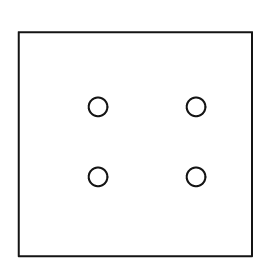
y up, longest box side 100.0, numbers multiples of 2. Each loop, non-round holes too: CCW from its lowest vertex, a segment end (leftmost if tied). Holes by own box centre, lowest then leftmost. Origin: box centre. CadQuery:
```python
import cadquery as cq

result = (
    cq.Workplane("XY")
    .moveTo(-50.0, -48.0)
    .lineTo(50.0, -48.0)
    .lineTo(50.0, 48.0)
    .lineTo(-50.0, 48.0)
    .close()
    .moveTo(-16.0, -14.0)
    .circle(4.0)
    .moveTo(26.0, -14.0)
    .circle(4.0)
    .moveTo(-16.0, 16.0)
    .circle(4.0)
    .moveTo(26.0, 16.0)
    .circle(4.0)
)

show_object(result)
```